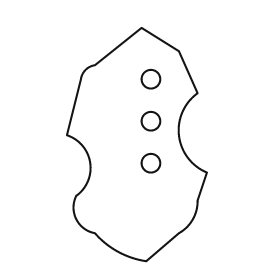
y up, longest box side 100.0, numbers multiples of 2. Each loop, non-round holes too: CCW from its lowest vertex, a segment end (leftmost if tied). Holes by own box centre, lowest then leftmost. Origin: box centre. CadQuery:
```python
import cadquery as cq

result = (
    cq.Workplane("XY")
    .moveTo(4.0, -50.0)
    .lineTo(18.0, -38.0)
    .threePointArc((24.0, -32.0), (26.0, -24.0))
    .lineTo(30.0, -12.0)
    .threePointArc((18.0, 4.0), (26.0, 22.0))
    .lineTo(18.0, 40.0)
    .lineTo(2.0, 50.0)
    .lineTo(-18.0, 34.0)
    .threePointArc((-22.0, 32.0), (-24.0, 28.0))
    .lineTo(-30.0, 4.0)
    .threePointArc((-20.0, -8.0), (-26.0, -22.0))
    .threePointArc((-26.0, -32.0), (-18.0, -38.0))
    .threePointArc((-8.0, -46.0), (4.0, -50.0))
    .close()
    .moveTo(6.0, -8.0)
    .circle(4.0)
    .moveTo(6.0, 10.0)
    .circle(4.0)
    .moveTo(6.0, 28.0)
    .circle(4.0)
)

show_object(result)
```